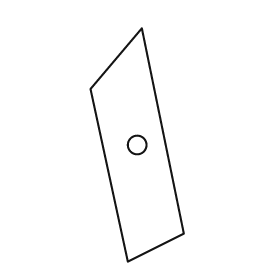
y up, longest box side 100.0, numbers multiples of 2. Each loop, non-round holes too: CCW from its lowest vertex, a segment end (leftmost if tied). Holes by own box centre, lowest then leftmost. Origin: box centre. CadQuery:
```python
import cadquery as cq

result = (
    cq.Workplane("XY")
    .moveTo(-4.0, -50.0)
    .lineTo(20.0, -38.0)
    .lineTo(2.0, 50.0)
    .lineTo(-20.0, 24.0)
    .close()
    .moveTo(0.0, 0.0)
    .circle(4.0)
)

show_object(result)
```